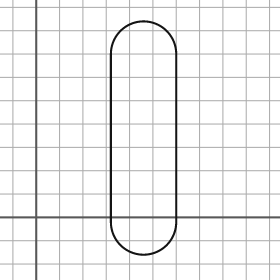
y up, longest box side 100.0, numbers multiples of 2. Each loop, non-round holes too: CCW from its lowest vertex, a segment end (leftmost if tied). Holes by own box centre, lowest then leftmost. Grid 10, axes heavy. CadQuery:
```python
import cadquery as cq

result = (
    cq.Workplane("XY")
    .moveTo(32.0, -2.0)
    .threePointArc((46.0, -16.0), (60.0, -2.0))
    .lineTo(60.0, 70.0)
    .threePointArc((46.0, 84.0), (32.0, 70.0))
    .close()
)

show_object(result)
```